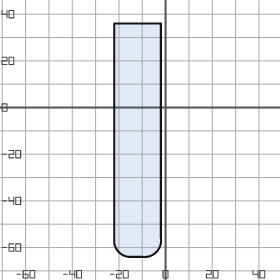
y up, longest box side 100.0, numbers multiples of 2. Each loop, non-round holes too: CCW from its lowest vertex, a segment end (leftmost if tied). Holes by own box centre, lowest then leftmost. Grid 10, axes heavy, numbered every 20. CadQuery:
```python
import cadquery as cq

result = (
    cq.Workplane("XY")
    .moveTo(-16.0, -64.0)
    .lineTo(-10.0, -64.0)
    .threePointArc((-4.0, -62.0), (-2.0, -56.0))
    .lineTo(-2.0, 36.0)
    .lineTo(-22.0, 36.0)
    .lineTo(-22.0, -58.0)
    .threePointArc((-20.0, -62.0), (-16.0, -64.0))
    .close()
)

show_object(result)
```